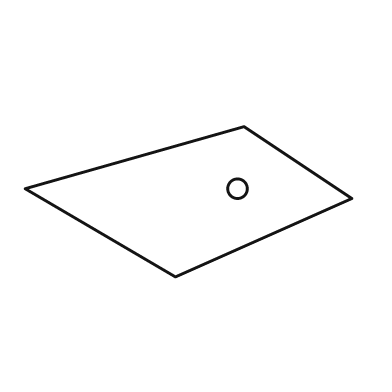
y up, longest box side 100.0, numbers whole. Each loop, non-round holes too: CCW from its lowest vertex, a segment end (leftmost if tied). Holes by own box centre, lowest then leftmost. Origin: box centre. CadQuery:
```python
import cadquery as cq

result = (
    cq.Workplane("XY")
    .moveTo(-4.0, -23.0)
    .lineTo(50.0, 1.0)
    .lineTo(17.0, 23.0)
    .lineTo(-50.0, 4.0)
    .close()
    .moveTo(15.0, 4.0)
    .circle(3.0)
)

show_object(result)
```